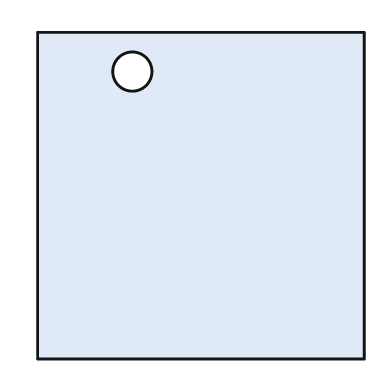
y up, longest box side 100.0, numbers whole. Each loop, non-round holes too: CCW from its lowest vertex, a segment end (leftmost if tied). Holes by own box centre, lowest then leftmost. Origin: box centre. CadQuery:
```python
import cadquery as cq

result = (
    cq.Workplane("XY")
    .moveTo(-50.0, -50.0)
    .lineTo(50.0, -50.0)
    .lineTo(50.0, 50.0)
    .lineTo(-50.0, 50.0)
    .close()
    .moveTo(-21.0, 38.0)
    .circle(6.0)
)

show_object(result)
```